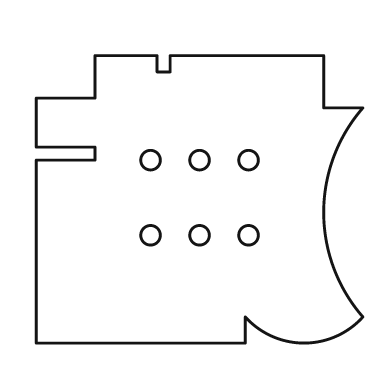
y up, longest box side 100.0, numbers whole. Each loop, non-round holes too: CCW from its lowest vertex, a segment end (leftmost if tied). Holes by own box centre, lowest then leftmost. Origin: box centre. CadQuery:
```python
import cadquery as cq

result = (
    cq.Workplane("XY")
    .moveTo(-50.0, -44.0)
    .lineTo(14.0, -44.0)
    .lineTo(14.0, -36.0)
    .threePointArc((32.0, -44.0), (50.0, -36.0))
    .threePointArc((38.0, -4.0), (50.0, 28.0))
    .lineTo(38.0, 28.0)
    .lineTo(38.0, 44.0)
    .lineTo(-9.0, 44.0)
    .lineTo(-9.0, 39.0)
    .lineTo(-13.0, 39.0)
    .lineTo(-13.0, 44.0)
    .lineTo(-32.0, 44.0)
    .lineTo(-32.0, 31.0)
    .lineTo(-50.0, 31.0)
    .lineTo(-50.0, 16.0)
    .lineTo(-32.0, 16.0)
    .lineTo(-32.0, 12.0)
    .lineTo(-50.0, 12.0)
    .close()
    .moveTo(-15.0, -11.0)
    .circle(3.0)
    .moveTo(0.0, -11.0)
    .circle(3.0)
    .moveTo(15.0, -11.0)
    .circle(3.0)
    .moveTo(-15.0, 12.0)
    .circle(3.0)
    .moveTo(0.0, 12.0)
    .circle(3.0)
    .moveTo(15.0, 12.0)
    .circle(3.0)
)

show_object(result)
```